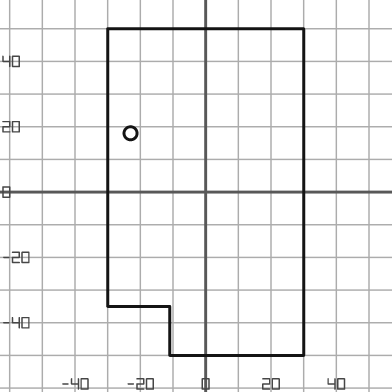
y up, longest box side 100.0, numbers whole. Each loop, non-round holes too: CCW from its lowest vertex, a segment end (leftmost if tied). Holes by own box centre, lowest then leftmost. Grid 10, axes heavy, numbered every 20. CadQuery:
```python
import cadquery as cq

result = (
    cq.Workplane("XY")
    .moveTo(-11.0, -50.0)
    .lineTo(30.0, -50.0)
    .lineTo(30.0, 50.0)
    .lineTo(-30.0, 50.0)
    .lineTo(-30.0, -35.0)
    .lineTo(-11.0, -35.0)
    .close()
    .moveTo(-23.0, 18.0)
    .circle(2.0)
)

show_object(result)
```